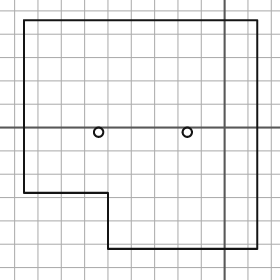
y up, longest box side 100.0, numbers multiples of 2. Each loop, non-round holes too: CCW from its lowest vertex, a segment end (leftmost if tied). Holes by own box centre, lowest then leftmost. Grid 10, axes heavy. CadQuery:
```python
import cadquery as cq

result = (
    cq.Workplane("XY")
    .moveTo(-50.0, -52.0)
    .lineTo(14.0, -52.0)
    .lineTo(14.0, 46.0)
    .lineTo(-86.0, 46.0)
    .lineTo(-86.0, -28.0)
    .lineTo(-50.0, -28.0)
    .close()
    .moveTo(-54.0, -2.0)
    .circle(2.0)
    .moveTo(-16.0, -2.0)
    .circle(2.0)
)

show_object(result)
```